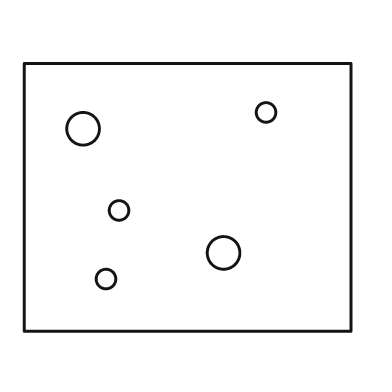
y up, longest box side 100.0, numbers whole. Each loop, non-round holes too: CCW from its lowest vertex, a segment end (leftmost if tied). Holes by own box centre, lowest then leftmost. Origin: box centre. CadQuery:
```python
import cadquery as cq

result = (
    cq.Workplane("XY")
    .moveTo(-50.0, -41.0)
    .lineTo(50.0, -41.0)
    .lineTo(50.0, 41.0)
    .lineTo(-50.0, 41.0)
    .close()
    .moveTo(-25.0, -25.0)
    .circle(3.0)
    .moveTo(11.0, -17.0)
    .circle(5.0)
    .moveTo(-21.0, -4.0)
    .circle(3.0)
    .moveTo(-32.0, 21.0)
    .circle(5.0)
    .moveTo(24.0, 26.0)
    .circle(3.0)
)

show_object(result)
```